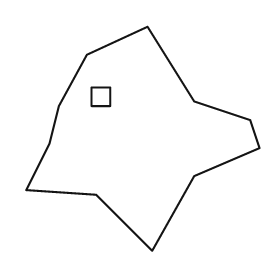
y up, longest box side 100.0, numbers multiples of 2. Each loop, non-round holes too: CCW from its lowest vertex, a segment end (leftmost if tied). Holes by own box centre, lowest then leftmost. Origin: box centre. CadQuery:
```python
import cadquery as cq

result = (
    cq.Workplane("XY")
    .moveTo(4.0, -48.0)
    .lineTo(22.0, -16.0)
    .lineTo(50.0, -4.0)
    .lineTo(46.0, 8.0)
    .lineTo(22.0, 16.0)
    .lineTo(2.0, 48.0)
    .lineTo(-24.0, 36.0)
    .lineTo(-36.0, 14.0)
    .lineTo(-40.0, -2.0)
    .lineTo(-50.0, -22.0)
    .lineTo(-20.0, -24.0)
    .close()
    .moveTo(-22.0, 14.0)
    .lineTo(-14.0, 14.0)
    .lineTo(-14.0, 22.0)
    .lineTo(-22.0, 22.0)
    .close()
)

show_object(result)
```